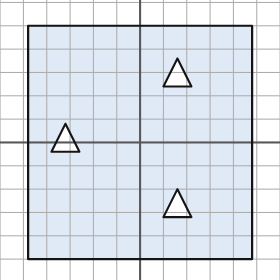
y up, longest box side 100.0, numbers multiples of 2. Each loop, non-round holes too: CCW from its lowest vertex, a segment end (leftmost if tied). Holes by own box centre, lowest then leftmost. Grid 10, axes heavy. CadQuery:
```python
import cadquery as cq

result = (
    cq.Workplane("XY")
    .moveTo(-48.0, -50.0)
    .lineTo(48.0, -50.0)
    .lineTo(48.0, 50.0)
    .lineTo(-48.0, 50.0)
    .close()
    .moveTo(10.0, -32.0)
    .lineTo(22.0, -32.0)
    .lineTo(16.0, -20.0)
    .close()
    .moveTo(-38.0, -4.0)
    .lineTo(-26.0, -4.0)
    .lineTo(-32.0, 8.0)
    .close()
    .moveTo(10.0, 24.0)
    .lineTo(22.0, 24.0)
    .lineTo(16.0, 36.0)
    .close()
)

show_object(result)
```